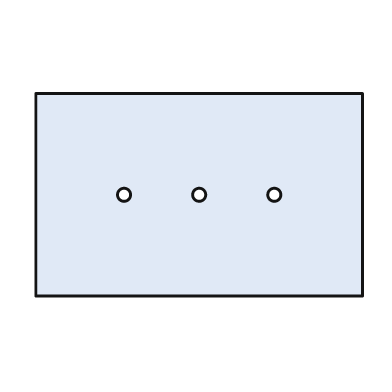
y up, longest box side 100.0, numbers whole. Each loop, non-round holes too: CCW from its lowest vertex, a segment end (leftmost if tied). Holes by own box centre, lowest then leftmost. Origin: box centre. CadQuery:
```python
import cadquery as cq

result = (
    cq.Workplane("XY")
    .moveTo(-50.0, -31.0)
    .lineTo(50.0, -31.0)
    .lineTo(50.0, 31.0)
    .lineTo(-50.0, 31.0)
    .close()
    .moveTo(-23.0, 0.0)
    .circle(2.0)
    .moveTo(0.0, 0.0)
    .circle(2.0)
    .moveTo(23.0, 0.0)
    .circle(2.0)
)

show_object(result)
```